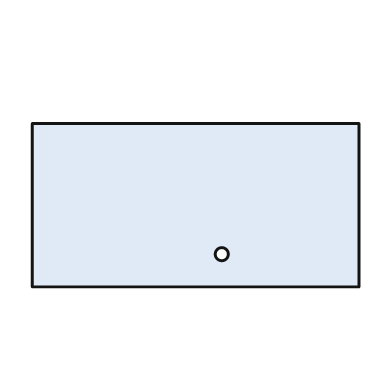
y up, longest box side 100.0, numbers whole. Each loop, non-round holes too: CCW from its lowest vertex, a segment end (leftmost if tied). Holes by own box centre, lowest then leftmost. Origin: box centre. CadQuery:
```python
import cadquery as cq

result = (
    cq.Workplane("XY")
    .moveTo(-50.0, -25.0)
    .lineTo(50.0, -25.0)
    .lineTo(50.0, 25.0)
    .lineTo(-50.0, 25.0)
    .close()
    .moveTo(8.0, -15.0)
    .circle(2.0)
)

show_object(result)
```